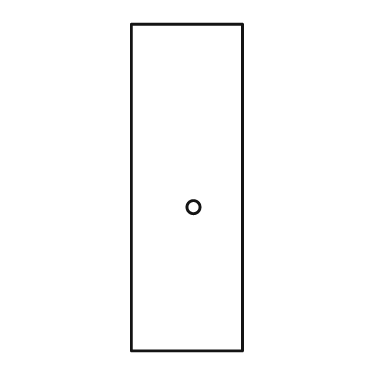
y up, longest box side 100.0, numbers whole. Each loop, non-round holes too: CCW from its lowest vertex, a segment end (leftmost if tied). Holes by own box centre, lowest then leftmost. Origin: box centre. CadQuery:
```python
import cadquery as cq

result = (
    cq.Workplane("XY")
    .moveTo(-17.0, -50.0)
    .lineTo(17.0, -50.0)
    .lineTo(17.0, 50.0)
    .lineTo(-17.0, 50.0)
    .close()
    .moveTo(2.0, -6.0)
    .circle(2.0)
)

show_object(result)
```